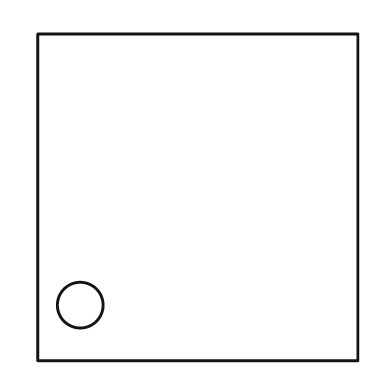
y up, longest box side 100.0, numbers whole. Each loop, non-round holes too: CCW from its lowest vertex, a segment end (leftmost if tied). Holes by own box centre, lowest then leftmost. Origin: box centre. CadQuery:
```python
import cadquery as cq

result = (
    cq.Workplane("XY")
    .moveTo(-49.0, -50.0)
    .lineTo(49.0, -50.0)
    .lineTo(49.0, 50.0)
    .lineTo(-49.0, 50.0)
    .close()
    .moveTo(-36.0, -33.0)
    .circle(7.0)
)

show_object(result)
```